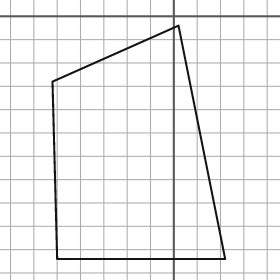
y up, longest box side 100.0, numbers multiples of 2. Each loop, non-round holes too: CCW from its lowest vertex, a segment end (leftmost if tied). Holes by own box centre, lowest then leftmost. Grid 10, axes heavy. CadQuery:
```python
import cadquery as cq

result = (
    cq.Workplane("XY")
    .moveTo(-50.0, -104.0)
    .lineTo(22.0, -104.0)
    .lineTo(2.0, -4.0)
    .lineTo(-52.0, -28.0)
    .close()
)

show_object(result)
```